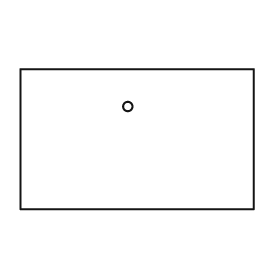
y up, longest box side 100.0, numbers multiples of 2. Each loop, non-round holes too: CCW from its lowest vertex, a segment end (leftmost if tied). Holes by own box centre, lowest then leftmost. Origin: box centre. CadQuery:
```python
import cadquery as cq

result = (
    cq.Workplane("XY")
    .moveTo(-50.0, -30.0)
    .lineTo(50.0, -30.0)
    .lineTo(50.0, 30.0)
    .lineTo(-50.0, 30.0)
    .close()
    .moveTo(-4.0, 14.0)
    .circle(2.0)
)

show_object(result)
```